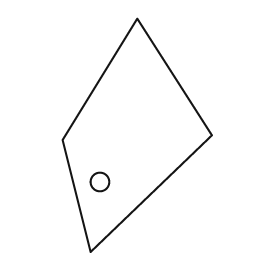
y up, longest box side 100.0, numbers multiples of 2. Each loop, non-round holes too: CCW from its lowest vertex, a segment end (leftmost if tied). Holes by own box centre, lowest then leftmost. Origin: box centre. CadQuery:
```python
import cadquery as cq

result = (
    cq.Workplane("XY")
    .moveTo(-20.0, -50.0)
    .lineTo(32.0, 0.0)
    .lineTo(0.0, 50.0)
    .lineTo(-32.0, -2.0)
    .close()
    .moveTo(-16.0, -20.0)
    .circle(4.0)
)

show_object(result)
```